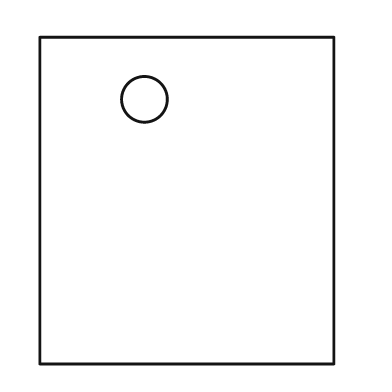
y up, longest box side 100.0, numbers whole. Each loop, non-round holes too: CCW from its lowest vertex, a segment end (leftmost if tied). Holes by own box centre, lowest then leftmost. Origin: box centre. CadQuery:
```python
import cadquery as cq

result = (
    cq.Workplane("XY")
    .moveTo(-45.0, -50.0)
    .lineTo(45.0, -50.0)
    .lineTo(45.0, 50.0)
    .lineTo(-45.0, 50.0)
    .close()
    .moveTo(-13.0, 31.0)
    .circle(7.0)
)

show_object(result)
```